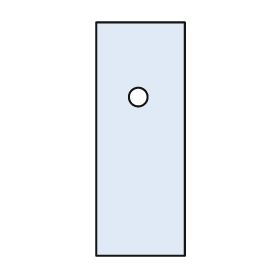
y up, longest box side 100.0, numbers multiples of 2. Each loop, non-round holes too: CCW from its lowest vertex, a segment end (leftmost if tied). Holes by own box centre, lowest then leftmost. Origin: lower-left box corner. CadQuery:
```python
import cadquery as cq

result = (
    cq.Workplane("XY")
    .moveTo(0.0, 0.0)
    .lineTo(38.0, 0.0)
    .lineTo(38.0, 100.0)
    .lineTo(0.0, 100.0)
    .close()
    .moveTo(18.0, 68.0)
    .circle(4.0)
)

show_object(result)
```